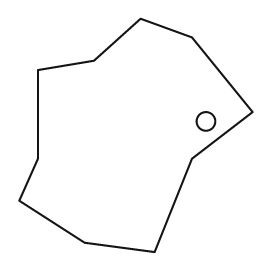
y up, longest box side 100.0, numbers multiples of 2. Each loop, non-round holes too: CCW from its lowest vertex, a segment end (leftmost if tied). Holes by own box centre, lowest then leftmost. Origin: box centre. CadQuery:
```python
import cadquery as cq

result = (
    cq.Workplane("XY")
    .moveTo(8.0, -50.0)
    .lineTo(24.0, -10.0)
    .lineTo(50.0, 10.0)
    .lineTo(24.0, 42.0)
    .lineTo(2.0, 50.0)
    .lineTo(-18.0, 32.0)
    .lineTo(-42.0, 28.0)
    .lineTo(-42.0, -10.0)
    .lineTo(-50.0, -28.0)
    .lineTo(-22.0, -46.0)
    .close()
    .moveTo(30.0, 6.0)
    .circle(4.0)
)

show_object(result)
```